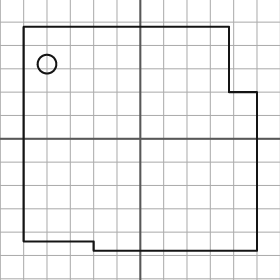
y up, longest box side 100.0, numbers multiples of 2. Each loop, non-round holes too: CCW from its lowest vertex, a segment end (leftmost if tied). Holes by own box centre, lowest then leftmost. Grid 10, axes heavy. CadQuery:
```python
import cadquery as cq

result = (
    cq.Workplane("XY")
    .moveTo(-20.0, -48.0)
    .lineTo(50.0, -48.0)
    .lineTo(50.0, 20.0)
    .lineTo(38.0, 20.0)
    .lineTo(38.0, 48.0)
    .lineTo(-50.0, 48.0)
    .lineTo(-50.0, -44.0)
    .lineTo(-20.0, -44.0)
    .close()
    .moveTo(-40.0, 32.0)
    .circle(4.0)
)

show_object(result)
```